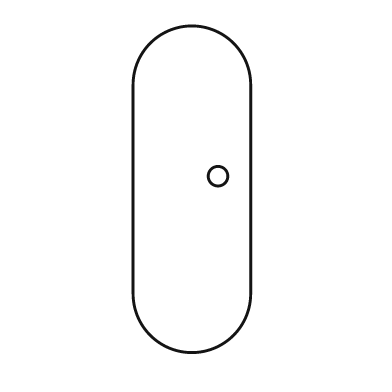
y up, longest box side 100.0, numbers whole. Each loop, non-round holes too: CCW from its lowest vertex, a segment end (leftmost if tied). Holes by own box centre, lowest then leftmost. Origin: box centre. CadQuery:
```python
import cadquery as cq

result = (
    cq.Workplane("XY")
    .moveTo(-18.0, -32.0)
    .threePointArc((0.0, -50.0), (18.0, -32.0))
    .lineTo(18.0, 32.0)
    .threePointArc((0.0, 50.0), (-18.0, 32.0))
    .close()
    .moveTo(8.0, 4.0)
    .circle(3.0)
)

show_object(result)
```